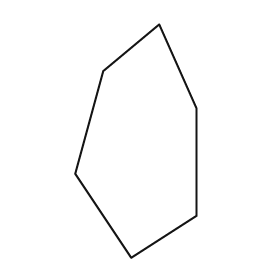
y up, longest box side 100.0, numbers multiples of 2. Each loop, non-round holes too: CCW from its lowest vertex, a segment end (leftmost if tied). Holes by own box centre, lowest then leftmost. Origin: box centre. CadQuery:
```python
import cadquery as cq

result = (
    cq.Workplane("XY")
    .moveTo(-2.0, -50.0)
    .lineTo(26.0, -32.0)
    .lineTo(26.0, 14.0)
    .lineTo(10.0, 50.0)
    .lineTo(-14.0, 30.0)
    .lineTo(-26.0, -14.0)
    .close()
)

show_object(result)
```